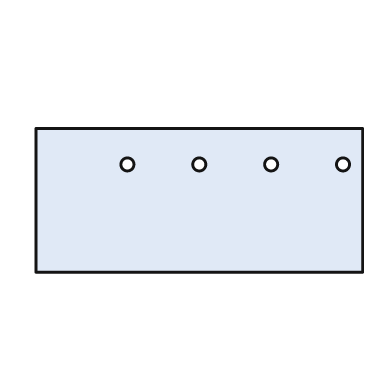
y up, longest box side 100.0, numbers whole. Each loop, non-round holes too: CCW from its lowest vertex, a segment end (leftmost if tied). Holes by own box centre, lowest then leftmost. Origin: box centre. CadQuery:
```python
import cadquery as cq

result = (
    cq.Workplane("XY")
    .moveTo(-50.0, -22.0)
    .lineTo(50.0, -22.0)
    .lineTo(50.0, 22.0)
    .lineTo(-50.0, 22.0)
    .close()
    .moveTo(-22.0, 11.0)
    .circle(2.0)
    .moveTo(0.0, 11.0)
    .circle(2.0)
    .moveTo(22.0, 11.0)
    .circle(2.0)
    .moveTo(44.0, 11.0)
    .circle(2.0)
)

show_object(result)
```